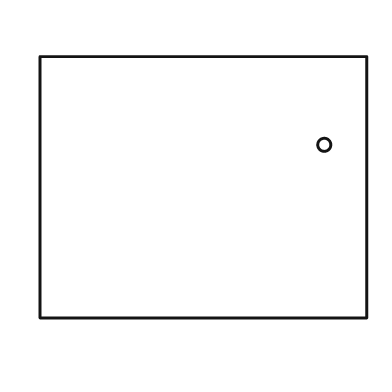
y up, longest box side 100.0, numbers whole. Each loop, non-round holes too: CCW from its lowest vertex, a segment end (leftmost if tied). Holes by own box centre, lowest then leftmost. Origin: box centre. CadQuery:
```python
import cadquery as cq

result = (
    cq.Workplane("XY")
    .moveTo(-50.0, -40.0)
    .lineTo(50.0, -40.0)
    .lineTo(50.0, 40.0)
    .lineTo(-50.0, 40.0)
    .close()
    .moveTo(37.0, 13.0)
    .circle(2.0)
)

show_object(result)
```